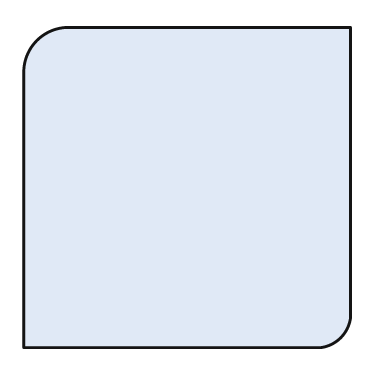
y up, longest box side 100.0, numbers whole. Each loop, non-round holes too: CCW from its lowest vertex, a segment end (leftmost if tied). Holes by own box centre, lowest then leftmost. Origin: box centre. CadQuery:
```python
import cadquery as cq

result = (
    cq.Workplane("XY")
    .moveTo(-50.0, -49.0)
    .lineTo(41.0, -49.0)
    .threePointArc((47.0, -46.0), (50.0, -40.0))
    .lineTo(50.0, 49.0)
    .lineTo(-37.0, 49.0)
    .threePointArc((-46.0, 45.0), (-50.0, 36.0))
    .close()
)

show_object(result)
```